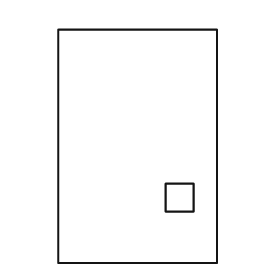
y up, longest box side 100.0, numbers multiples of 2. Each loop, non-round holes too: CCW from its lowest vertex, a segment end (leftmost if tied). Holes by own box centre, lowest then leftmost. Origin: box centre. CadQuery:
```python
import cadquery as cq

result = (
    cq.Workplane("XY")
    .moveTo(-34.0, -50.0)
    .lineTo(34.0, -50.0)
    .lineTo(34.0, 50.0)
    .lineTo(-34.0, 50.0)
    .close()
    .moveTo(12.0, -28.0)
    .lineTo(24.0, -28.0)
    .lineTo(24.0, -16.0)
    .lineTo(12.0, -16.0)
    .close()
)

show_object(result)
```